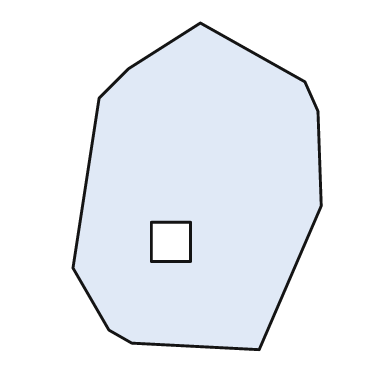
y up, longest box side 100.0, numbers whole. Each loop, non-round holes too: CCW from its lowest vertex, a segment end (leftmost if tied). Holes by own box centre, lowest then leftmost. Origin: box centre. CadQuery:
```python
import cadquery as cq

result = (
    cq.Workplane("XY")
    .moveTo(19.0, -50.0)
    .lineTo(38.0, -6.0)
    .lineTo(37.0, 23.0)
    .lineTo(33.0, 32.0)
    .lineTo(1.0, 50.0)
    .lineTo(-21.0, 36.0)
    .lineTo(-30.0, 27.0)
    .lineTo(-38.0, -25.0)
    .lineTo(-27.0, -44.0)
    .lineTo(-20.0, -48.0)
    .close()
    .moveTo(-14.0, -23.0)
    .lineTo(-2.0, -23.0)
    .lineTo(-2.0, -11.0)
    .lineTo(-14.0, -11.0)
    .close()
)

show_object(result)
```